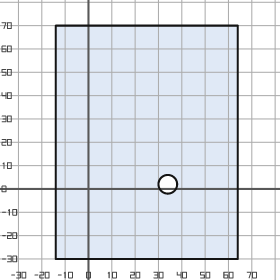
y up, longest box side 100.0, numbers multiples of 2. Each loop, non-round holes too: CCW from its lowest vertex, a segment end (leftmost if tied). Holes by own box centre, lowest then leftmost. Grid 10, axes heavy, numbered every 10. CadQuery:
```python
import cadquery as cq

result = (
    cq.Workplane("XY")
    .moveTo(-14.0, -30.0)
    .lineTo(64.0, -30.0)
    .lineTo(64.0, 70.0)
    .lineTo(-14.0, 70.0)
    .close()
    .moveTo(34.0, 2.0)
    .circle(4.0)
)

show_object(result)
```